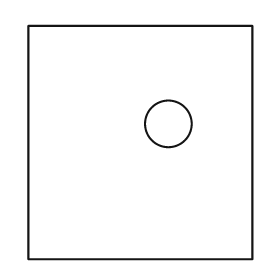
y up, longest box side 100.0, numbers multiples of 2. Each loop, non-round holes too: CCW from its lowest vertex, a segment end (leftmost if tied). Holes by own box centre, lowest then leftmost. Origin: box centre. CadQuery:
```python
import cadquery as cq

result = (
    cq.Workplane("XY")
    .moveTo(-48.0, -50.0)
    .lineTo(48.0, -50.0)
    .lineTo(48.0, 50.0)
    .lineTo(-48.0, 50.0)
    .close()
    .moveTo(12.0, 8.0)
    .circle(10.0)
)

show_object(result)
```